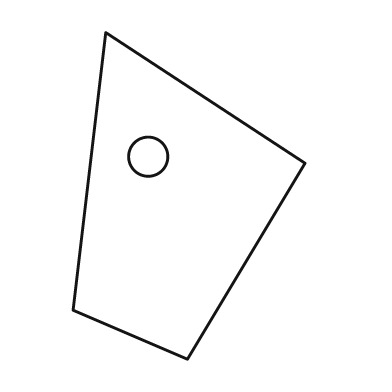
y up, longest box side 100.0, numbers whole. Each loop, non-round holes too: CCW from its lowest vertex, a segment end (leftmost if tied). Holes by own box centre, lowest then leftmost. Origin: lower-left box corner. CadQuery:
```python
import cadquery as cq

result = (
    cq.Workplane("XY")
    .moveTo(35.0, 0.0)
    .lineTo(71.0, 60.0)
    .lineTo(10.0, 100.0)
    .lineTo(0.0, 15.0)
    .close()
    .moveTo(23.0, 62.0)
    .circle(6.0)
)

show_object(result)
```